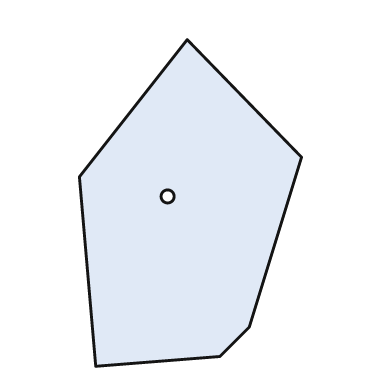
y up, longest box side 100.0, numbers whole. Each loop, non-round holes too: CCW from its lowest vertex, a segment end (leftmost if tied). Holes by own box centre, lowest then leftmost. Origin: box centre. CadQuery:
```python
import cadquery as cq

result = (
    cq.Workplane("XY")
    .moveTo(-29.0, -50.0)
    .lineTo(9.0, -47.0)
    .lineTo(18.0, -38.0)
    .lineTo(34.0, 14.0)
    .lineTo(-1.0, 50.0)
    .lineTo(-34.0, 8.0)
    .close()
    .moveTo(-7.0, 2.0)
    .circle(2.0)
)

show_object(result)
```